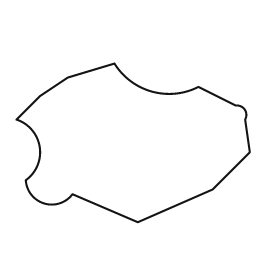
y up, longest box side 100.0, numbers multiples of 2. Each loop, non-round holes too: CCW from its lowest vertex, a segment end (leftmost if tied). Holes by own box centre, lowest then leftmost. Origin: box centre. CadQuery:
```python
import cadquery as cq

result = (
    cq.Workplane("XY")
    .moveTo(2.0, -34.0)
    .lineTo(34.0, -20.0)
    .lineTo(50.0, -4.0)
    .lineTo(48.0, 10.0)
    .threePointArc((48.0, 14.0), (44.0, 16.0))
    .lineTo(28.0, 24.0)
    .threePointArc((8.0, 22.0), (-8.0, 34.0))
    .lineTo(-28.0, 28.0)
    .lineTo(-40.0, 20.0)
    .lineTo(-50.0, 10.0)
    .threePointArc((-40.0, -2.0), (-46.0, -16.0))
    .threePointArc((-38.0, -26.0), (-26.0, -22.0))
    .close()
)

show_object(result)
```